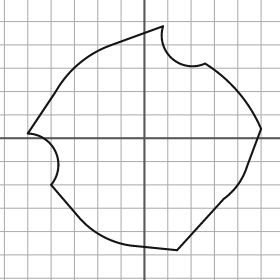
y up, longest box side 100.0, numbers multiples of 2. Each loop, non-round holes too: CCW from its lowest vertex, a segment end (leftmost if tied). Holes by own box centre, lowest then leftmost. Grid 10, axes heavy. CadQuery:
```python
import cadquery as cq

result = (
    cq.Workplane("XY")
    .moveTo(14.0, -48.0)
    .lineTo(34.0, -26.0)
    .threePointArc((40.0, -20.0), (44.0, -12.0))
    .lineTo(50.0, 4.0)
    .threePointArc((40.0, 20.0), (26.0, 32.0))
    .threePointArc((12.0, 34.0), (8.0, 48.0))
    .lineTo(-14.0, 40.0)
    .threePointArc((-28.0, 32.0), (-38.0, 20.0))
    .lineTo(-50.0, 2.0)
    .threePointArc((-38.0, -6.0), (-40.0, -20.0))
    .lineTo(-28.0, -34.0)
    .threePointArc((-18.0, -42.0), (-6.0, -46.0))
    .close()
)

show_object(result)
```